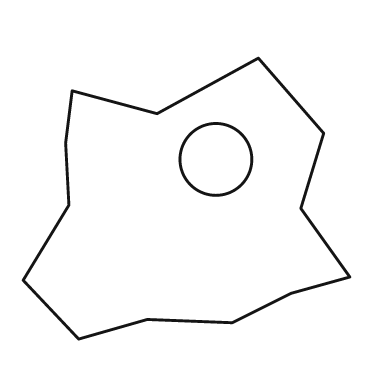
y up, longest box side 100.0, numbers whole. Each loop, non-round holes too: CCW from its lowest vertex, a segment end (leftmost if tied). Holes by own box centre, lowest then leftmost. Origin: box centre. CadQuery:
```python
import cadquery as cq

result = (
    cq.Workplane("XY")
    .moveTo(-33.0, -43.0)
    .lineTo(-12.0, -37.0)
    .lineTo(14.0, -38.0)
    .lineTo(32.0, -29.0)
    .lineTo(50.0, -24.0)
    .lineTo(35.0, -3.0)
    .lineTo(42.0, 20.0)
    .lineTo(22.0, 43.0)
    .lineTo(-9.0, 26.0)
    .lineTo(-35.0, 33.0)
    .lineTo(-37.0, 17.0)
    .lineTo(-36.0, -2.0)
    .lineTo(-50.0, -25.0)
    .close()
    .moveTo(9.0, 12.0)
    .circle(11.0)
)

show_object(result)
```